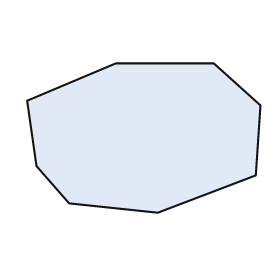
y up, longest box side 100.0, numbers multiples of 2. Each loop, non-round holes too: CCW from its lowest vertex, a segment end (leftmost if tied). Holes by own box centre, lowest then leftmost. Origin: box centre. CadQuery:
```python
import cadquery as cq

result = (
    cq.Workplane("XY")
    .moveTo(6.0, -32.0)
    .lineTo(48.0, -16.0)
    .lineTo(50.0, 14.0)
    .lineTo(30.0, 32.0)
    .lineTo(-12.0, 32.0)
    .lineTo(-50.0, 16.0)
    .lineTo(-46.0, -12.0)
    .lineTo(-32.0, -28.0)
    .close()
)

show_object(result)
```